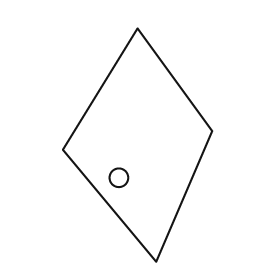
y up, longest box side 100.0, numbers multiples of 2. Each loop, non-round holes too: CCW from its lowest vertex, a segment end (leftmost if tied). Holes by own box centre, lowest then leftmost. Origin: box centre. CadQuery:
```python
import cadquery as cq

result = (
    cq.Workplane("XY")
    .moveTo(8.0, -50.0)
    .lineTo(32.0, 6.0)
    .lineTo(0.0, 50.0)
    .lineTo(-32.0, -2.0)
    .close()
    .moveTo(-8.0, -14.0)
    .circle(4.0)
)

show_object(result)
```